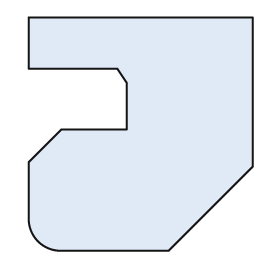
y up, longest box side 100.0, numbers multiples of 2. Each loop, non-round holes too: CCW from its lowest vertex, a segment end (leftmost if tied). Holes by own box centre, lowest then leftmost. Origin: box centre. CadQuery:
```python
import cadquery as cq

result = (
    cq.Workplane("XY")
    .moveTo(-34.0, -50.0)
    .lineTo(12.0, -50.0)
    .lineTo(48.0, -14.0)
    .lineTo(48.0, 50.0)
    .lineTo(-48.0, 50.0)
    .lineTo(-48.0, 28.0)
    .lineTo(-10.0, 28.0)
    .lineTo(-6.0, 22.0)
    .lineTo(-6.0, 2.0)
    .lineTo(-34.0, 2.0)
    .lineTo(-48.0, -12.0)
    .lineTo(-48.0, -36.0)
    .threePointArc((-44.0, -46.0), (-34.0, -50.0))
    .close()
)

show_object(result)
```